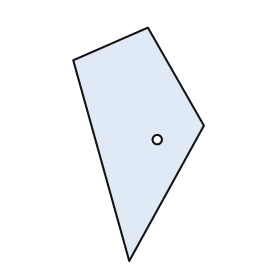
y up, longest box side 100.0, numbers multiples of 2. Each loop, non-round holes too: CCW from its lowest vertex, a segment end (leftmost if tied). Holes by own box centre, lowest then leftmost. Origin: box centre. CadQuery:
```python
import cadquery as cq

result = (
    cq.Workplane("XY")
    .moveTo(-4.0, -50.0)
    .lineTo(28.0, 8.0)
    .lineTo(4.0, 50.0)
    .lineTo(-28.0, 36.0)
    .close()
    .moveTo(8.0, 2.0)
    .circle(2.0)
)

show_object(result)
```